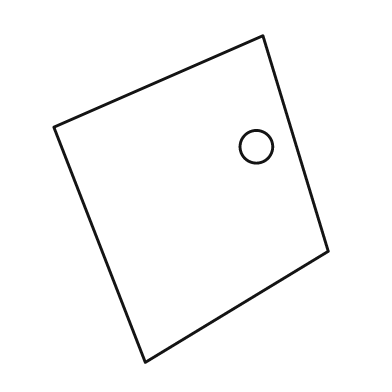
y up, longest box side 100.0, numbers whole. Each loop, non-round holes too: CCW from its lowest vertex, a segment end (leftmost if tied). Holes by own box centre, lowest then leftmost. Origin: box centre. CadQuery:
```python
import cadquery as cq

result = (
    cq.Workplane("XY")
    .moveTo(-14.0, -50.0)
    .lineTo(42.0, -16.0)
    .lineTo(22.0, 50.0)
    .lineTo(-42.0, 22.0)
    .close()
    .moveTo(20.0, 16.0)
    .circle(5.0)
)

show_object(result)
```